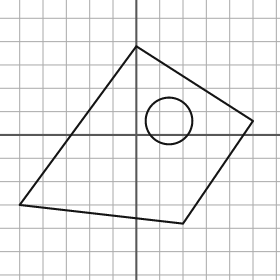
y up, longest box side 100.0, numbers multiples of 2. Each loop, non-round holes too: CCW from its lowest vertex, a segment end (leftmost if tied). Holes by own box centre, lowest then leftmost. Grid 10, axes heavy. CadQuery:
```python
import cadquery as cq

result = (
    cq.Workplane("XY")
    .moveTo(20.0, -38.0)
    .lineTo(50.0, 6.0)
    .lineTo(0.0, 38.0)
    .lineTo(-50.0, -30.0)
    .close()
    .moveTo(14.0, 6.0)
    .circle(10.0)
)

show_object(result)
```